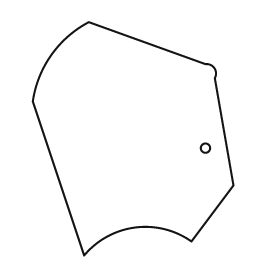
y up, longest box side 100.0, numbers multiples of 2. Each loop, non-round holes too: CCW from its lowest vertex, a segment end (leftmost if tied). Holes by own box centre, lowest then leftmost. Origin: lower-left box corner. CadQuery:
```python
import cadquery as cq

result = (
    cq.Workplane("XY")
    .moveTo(22.0, 0.0)
    .threePointArc((44.0, 12.0), (68.0, 6.0))
    .lineTo(86.0, 30.0)
    .lineTo(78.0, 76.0)
    .threePointArc((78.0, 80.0), (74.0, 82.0))
    .lineTo(24.0, 100.0)
    .threePointArc((8.0, 86.0), (0.0, 66.0))
    .close()
    .moveTo(74.0, 46.0)
    .circle(2.0)
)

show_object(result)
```